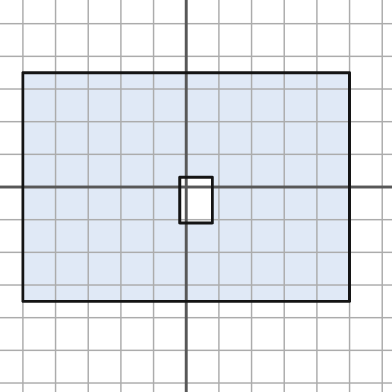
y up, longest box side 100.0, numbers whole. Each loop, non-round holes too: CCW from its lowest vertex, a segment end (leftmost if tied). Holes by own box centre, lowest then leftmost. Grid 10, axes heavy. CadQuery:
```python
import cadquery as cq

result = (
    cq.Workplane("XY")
    .moveTo(-50.0, -35.0)
    .lineTo(50.0, -35.0)
    .lineTo(50.0, 35.0)
    .lineTo(-50.0, 35.0)
    .close()
    .moveTo(-2.0, -11.0)
    .lineTo(8.0, -11.0)
    .lineTo(8.0, 3.0)
    .lineTo(-2.0, 3.0)
    .close()
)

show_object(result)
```